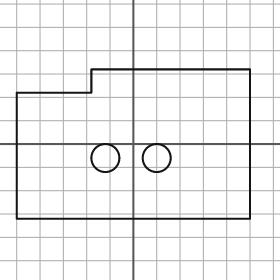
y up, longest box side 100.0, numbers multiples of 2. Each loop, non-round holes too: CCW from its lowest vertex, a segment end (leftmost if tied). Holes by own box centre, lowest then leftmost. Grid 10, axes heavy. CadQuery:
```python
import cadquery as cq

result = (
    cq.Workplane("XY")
    .moveTo(-50.0, -32.0)
    .lineTo(50.0, -32.0)
    .lineTo(50.0, 32.0)
    .lineTo(-18.0, 32.0)
    .lineTo(-18.0, 22.0)
    .lineTo(-50.0, 22.0)
    .close()
    .moveTo(-12.0, -6.0)
    .circle(6.0)
    .moveTo(10.0, -6.0)
    .circle(6.0)
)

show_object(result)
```